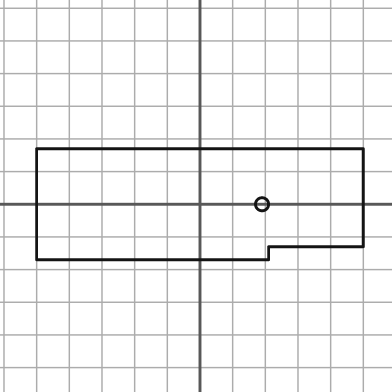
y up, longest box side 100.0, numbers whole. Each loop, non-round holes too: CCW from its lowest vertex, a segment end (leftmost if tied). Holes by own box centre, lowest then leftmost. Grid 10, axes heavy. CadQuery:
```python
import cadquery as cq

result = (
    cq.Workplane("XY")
    .moveTo(-50.0, -17.0)
    .lineTo(21.0, -17.0)
    .lineTo(21.0, -13.0)
    .lineTo(50.0, -13.0)
    .lineTo(50.0, 17.0)
    .lineTo(-50.0, 17.0)
    .close()
    .moveTo(19.0, 0.0)
    .circle(2.0)
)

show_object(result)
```